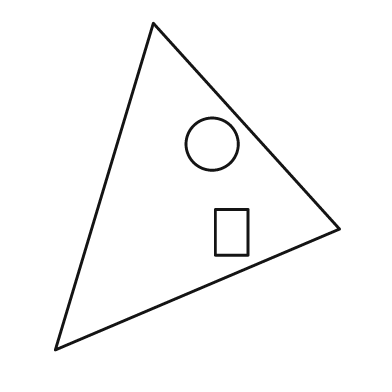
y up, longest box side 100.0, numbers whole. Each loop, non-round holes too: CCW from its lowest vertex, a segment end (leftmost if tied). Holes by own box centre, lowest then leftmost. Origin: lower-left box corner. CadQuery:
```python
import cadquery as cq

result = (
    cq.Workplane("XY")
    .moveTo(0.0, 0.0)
    .lineTo(87.0, 37.0)
    .lineTo(30.0, 100.0)
    .close()
    .moveTo(49.0, 29.0)
    .lineTo(59.0, 29.0)
    .lineTo(59.0, 43.0)
    .lineTo(49.0, 43.0)
    .close()
    .moveTo(48.0, 63.0)
    .circle(8.0)
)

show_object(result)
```